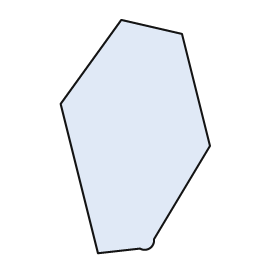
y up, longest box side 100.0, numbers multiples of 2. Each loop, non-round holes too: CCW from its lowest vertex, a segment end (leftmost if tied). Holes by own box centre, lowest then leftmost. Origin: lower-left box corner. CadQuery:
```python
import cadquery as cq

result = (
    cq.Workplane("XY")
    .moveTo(16.0, 0.0)
    .lineTo(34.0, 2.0)
    .threePointArc((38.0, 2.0), (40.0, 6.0))
    .lineTo(64.0, 46.0)
    .lineTo(52.0, 94.0)
    .lineTo(26.0, 100.0)
    .lineTo(0.0, 64.0)
    .close()
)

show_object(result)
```